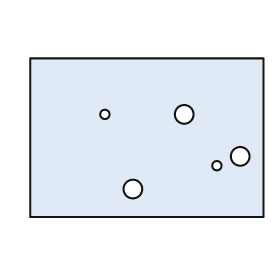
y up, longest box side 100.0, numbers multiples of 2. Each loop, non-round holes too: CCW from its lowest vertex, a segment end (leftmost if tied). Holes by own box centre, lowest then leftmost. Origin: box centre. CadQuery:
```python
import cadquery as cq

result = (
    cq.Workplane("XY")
    .moveTo(-50.0, -34.0)
    .lineTo(50.0, -34.0)
    .lineTo(50.0, 34.0)
    .lineTo(-50.0, 34.0)
    .close()
    .moveTo(-6.0, -22.0)
    .circle(4.0)
    .moveTo(30.0, -12.0)
    .circle(2.0)
    .moveTo(40.0, -8.0)
    .circle(4.0)
    .moveTo(-18.0, 10.0)
    .circle(2.0)
    .moveTo(16.0, 10.0)
    .circle(4.0)
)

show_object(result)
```